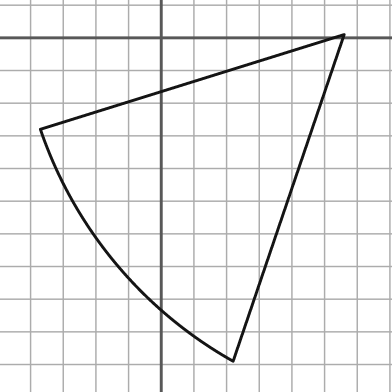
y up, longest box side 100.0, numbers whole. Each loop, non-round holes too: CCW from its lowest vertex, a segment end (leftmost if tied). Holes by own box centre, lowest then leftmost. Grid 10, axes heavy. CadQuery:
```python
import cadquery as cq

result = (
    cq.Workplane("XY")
    .moveTo(22.0, -99.0)
    .lineTo(56.0, 1.0)
    .lineTo(-37.0, -28.0)
    .threePointArc((-14.0, -69.0), (22.0, -99.0))
    .close()
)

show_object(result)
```